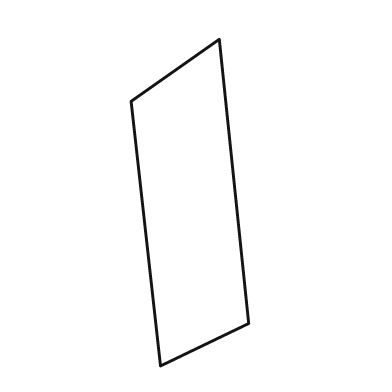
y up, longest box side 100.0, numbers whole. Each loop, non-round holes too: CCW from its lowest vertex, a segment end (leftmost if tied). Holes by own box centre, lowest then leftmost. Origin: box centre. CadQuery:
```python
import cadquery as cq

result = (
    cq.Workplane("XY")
    .moveTo(-9.0, -50.0)
    .lineTo(18.0, -37.0)
    .lineTo(9.0, 50.0)
    .lineTo(-18.0, 31.0)
    .close()
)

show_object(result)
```